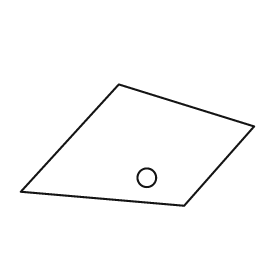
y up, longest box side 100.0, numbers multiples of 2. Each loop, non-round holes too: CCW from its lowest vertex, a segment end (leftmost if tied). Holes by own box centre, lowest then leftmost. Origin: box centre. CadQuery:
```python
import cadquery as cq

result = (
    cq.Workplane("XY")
    .moveTo(20.0, -26.0)
    .lineTo(50.0, 8.0)
    .lineTo(-8.0, 26.0)
    .lineTo(-50.0, -20.0)
    .close()
    .moveTo(4.0, -14.0)
    .circle(4.0)
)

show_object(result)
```